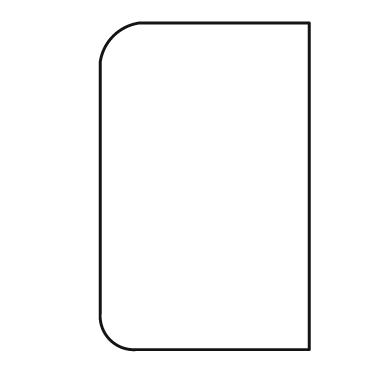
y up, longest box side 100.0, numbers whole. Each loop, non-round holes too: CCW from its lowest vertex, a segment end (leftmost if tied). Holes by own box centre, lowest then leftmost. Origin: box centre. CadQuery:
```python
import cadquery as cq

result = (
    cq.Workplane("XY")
    .moveTo(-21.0, -50.0)
    .lineTo(32.0, -50.0)
    .lineTo(32.0, 50.0)
    .lineTo(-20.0, 50.0)
    .threePointArc((-28.0, 46.0), (-32.0, 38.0))
    .lineTo(-32.0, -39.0)
    .threePointArc((-29.0, -47.0), (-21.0, -50.0))
    .close()
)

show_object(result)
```